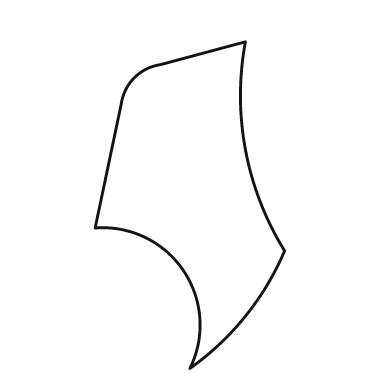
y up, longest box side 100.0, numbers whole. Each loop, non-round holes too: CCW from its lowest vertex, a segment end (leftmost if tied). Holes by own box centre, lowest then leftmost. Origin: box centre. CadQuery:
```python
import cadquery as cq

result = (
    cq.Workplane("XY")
    .moveTo(0.0, -50.0)
    .threePointArc((17.0, -34.0), (29.0, -14.0))
    .threePointArc((17.0, 17.0), (17.0, 50.0))
    .lineTo(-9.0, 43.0)
    .threePointArc((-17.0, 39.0), (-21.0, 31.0))
    .lineTo(-29.0, -7.0)
    .threePointArc((-2.0, -20.0), (0.0, -50.0))
    .close()
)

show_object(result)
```